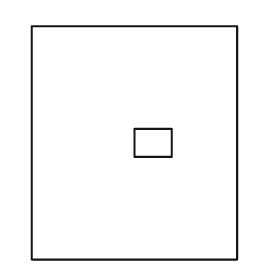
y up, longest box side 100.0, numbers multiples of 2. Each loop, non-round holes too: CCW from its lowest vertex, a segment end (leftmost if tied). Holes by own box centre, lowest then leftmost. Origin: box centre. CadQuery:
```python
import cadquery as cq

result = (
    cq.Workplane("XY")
    .moveTo(-44.0, -50.0)
    .lineTo(44.0, -50.0)
    .lineTo(44.0, 50.0)
    .lineTo(-44.0, 50.0)
    .close()
    .moveTo(0.0, -6.0)
    .lineTo(16.0, -6.0)
    .lineTo(16.0, 6.0)
    .lineTo(0.0, 6.0)
    .close()
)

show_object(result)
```